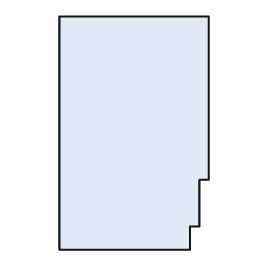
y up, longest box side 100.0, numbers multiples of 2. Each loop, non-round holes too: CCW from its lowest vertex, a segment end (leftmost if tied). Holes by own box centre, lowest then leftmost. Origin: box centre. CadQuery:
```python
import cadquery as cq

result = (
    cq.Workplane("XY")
    .moveTo(-32.0, -50.0)
    .lineTo(24.0, -50.0)
    .lineTo(24.0, -40.0)
    .lineTo(28.0, -40.0)
    .lineTo(28.0, -20.0)
    .lineTo(32.0, -20.0)
    .lineTo(32.0, 50.0)
    .lineTo(-32.0, 50.0)
    .close()
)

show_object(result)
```